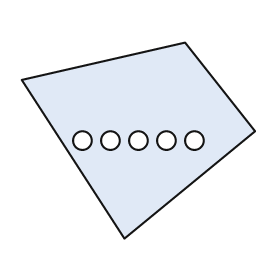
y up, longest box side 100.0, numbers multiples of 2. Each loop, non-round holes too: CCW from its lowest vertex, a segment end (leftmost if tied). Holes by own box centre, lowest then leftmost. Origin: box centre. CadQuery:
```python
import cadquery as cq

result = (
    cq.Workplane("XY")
    .moveTo(-6.0, -42.0)
    .lineTo(50.0, 4.0)
    .lineTo(20.0, 42.0)
    .lineTo(-50.0, 26.0)
    .close()
    .moveTo(-24.0, 0.0)
    .circle(4.0)
    .moveTo(-12.0, 0.0)
    .circle(4.0)
    .moveTo(0.0, 0.0)
    .circle(4.0)
    .moveTo(12.0, 0.0)
    .circle(4.0)
    .moveTo(24.0, 0.0)
    .circle(4.0)
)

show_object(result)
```